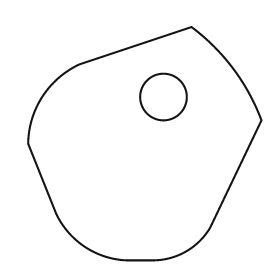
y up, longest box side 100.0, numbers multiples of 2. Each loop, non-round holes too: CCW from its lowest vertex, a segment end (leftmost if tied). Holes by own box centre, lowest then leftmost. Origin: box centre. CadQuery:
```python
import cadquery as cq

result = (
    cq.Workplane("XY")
    .moveTo(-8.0, -50.0)
    .lineTo(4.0, -50.0)
    .threePointArc((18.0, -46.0), (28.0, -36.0))
    .lineTo(50.0, 10.0)
    .threePointArc((38.0, 32.0), (20.0, 50.0))
    .lineTo(-28.0, 34.0)
    .threePointArc((-44.0, 20.0), (-50.0, 0.0))
    .lineTo(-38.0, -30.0)
    .threePointArc((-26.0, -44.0), (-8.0, -50.0))
    .close()
    .moveTo(8.0, 20.0)
    .circle(10.0)
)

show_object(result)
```